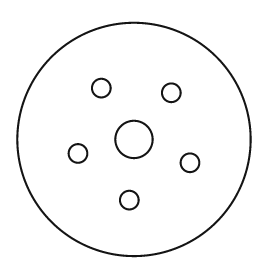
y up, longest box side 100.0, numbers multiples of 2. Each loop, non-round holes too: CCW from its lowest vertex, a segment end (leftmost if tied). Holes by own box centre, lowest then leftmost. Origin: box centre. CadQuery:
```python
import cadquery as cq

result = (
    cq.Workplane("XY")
    .moveTo(0.0, 0.0)
    .circle(50.0)
    .moveTo(-2.0, -26.0)
    .circle(4.0)
    .moveTo(24.0, -10.0)
    .circle(4.0)
    .moveTo(-24.0, -6.0)
    .circle(4.0)
    .moveTo(0.0, 0.0)
    .circle(8.0)
    .moveTo(16.0, 20.0)
    .circle(4.0)
    .moveTo(-14.0, 22.0)
    .circle(4.0)
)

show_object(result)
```